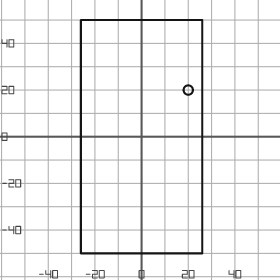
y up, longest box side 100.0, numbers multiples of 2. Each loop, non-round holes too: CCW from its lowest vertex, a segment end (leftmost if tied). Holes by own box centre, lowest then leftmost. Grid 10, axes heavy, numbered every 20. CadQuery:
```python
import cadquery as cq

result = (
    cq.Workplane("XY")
    .moveTo(-26.0, -50.0)
    .lineTo(26.0, -50.0)
    .lineTo(26.0, 50.0)
    .lineTo(-26.0, 50.0)
    .close()
    .moveTo(20.0, 20.0)
    .circle(2.0)
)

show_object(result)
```